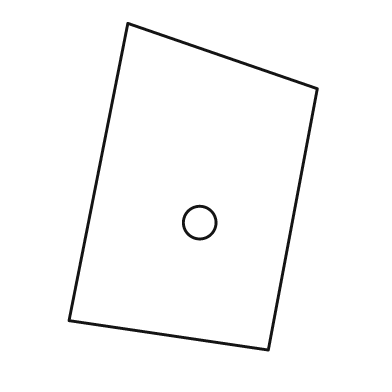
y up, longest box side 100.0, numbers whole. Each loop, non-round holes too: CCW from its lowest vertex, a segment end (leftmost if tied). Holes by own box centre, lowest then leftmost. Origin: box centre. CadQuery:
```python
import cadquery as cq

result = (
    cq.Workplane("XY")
    .moveTo(23.0, -50.0)
    .lineTo(38.0, 30.0)
    .lineTo(-20.0, 50.0)
    .lineTo(-38.0, -41.0)
    .close()
    .moveTo(2.0, -11.0)
    .circle(5.0)
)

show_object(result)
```